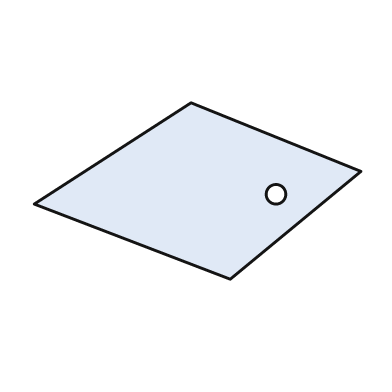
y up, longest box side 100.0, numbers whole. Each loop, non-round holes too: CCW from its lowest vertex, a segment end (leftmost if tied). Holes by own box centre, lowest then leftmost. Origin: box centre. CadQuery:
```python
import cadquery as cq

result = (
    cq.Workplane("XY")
    .moveTo(10.0, -27.0)
    .lineTo(50.0, 6.0)
    .lineTo(-2.0, 27.0)
    .lineTo(-50.0, -4.0)
    .close()
    .moveTo(24.0, -1.0)
    .circle(3.0)
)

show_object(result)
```